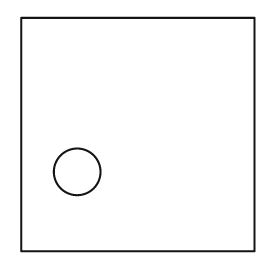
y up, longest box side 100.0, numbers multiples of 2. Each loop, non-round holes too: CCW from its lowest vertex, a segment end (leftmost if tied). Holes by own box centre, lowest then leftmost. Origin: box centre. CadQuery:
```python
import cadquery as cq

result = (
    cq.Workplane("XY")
    .moveTo(-50.0, -50.0)
    .lineTo(50.0, -50.0)
    .lineTo(50.0, 50.0)
    .lineTo(-50.0, 50.0)
    .close()
    .moveTo(-26.0, -16.0)
    .circle(10.0)
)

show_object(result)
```